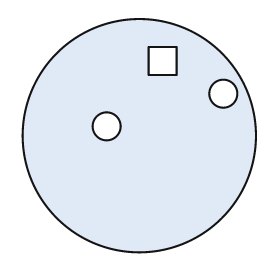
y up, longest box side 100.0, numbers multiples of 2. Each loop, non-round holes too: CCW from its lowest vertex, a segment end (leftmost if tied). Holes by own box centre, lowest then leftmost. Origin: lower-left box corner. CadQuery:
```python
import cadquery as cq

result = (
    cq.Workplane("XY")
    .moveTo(50.0, 50.0)
    .circle(50.0)
    .moveTo(36.0, 54.0)
    .circle(6.0)
    .moveTo(86.0, 68.0)
    .circle(6.0)
    .moveTo(54.0, 76.0)
    .lineTo(66.0, 76.0)
    .lineTo(66.0, 88.0)
    .lineTo(54.0, 88.0)
    .close()
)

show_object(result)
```